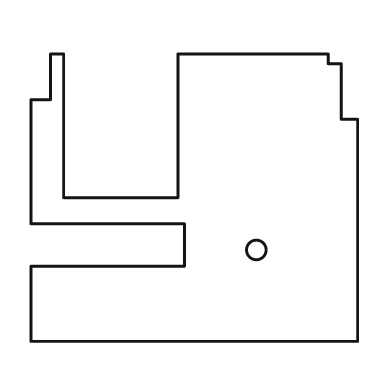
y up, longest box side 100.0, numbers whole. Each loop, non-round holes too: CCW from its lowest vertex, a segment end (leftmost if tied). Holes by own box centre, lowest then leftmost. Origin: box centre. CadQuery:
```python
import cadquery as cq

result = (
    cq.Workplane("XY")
    .moveTo(-50.0, -44.0)
    .lineTo(50.0, -44.0)
    .lineTo(50.0, 24.0)
    .lineTo(45.0, 24.0)
    .lineTo(45.0, 41.0)
    .lineTo(41.0, 41.0)
    .lineTo(41.0, 44.0)
    .lineTo(-5.0, 44.0)
    .lineTo(-5.0, 0.0)
    .lineTo(-40.0, 0.0)
    .lineTo(-40.0, 44.0)
    .lineTo(-44.0, 44.0)
    .lineTo(-44.0, 30.0)
    .lineTo(-50.0, 30.0)
    .lineTo(-50.0, -8.0)
    .lineTo(-3.0, -8.0)
    .lineTo(-3.0, -21.0)
    .lineTo(-50.0, -21.0)
    .close()
    .moveTo(19.0, -16.0)
    .circle(3.0)
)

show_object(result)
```